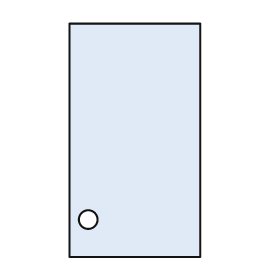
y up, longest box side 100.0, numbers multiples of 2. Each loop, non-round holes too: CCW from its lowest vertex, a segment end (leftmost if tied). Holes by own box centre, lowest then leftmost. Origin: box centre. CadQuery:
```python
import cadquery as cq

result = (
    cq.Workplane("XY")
    .moveTo(-28.0, -50.0)
    .lineTo(28.0, -50.0)
    .lineTo(28.0, 50.0)
    .lineTo(-28.0, 50.0)
    .close()
    .moveTo(-20.0, -34.0)
    .circle(4.0)
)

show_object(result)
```